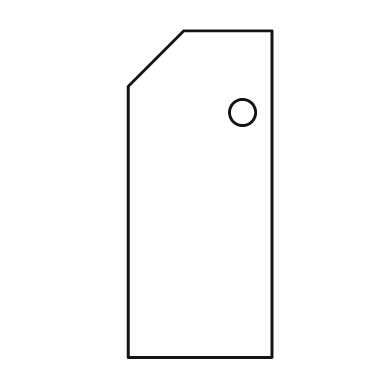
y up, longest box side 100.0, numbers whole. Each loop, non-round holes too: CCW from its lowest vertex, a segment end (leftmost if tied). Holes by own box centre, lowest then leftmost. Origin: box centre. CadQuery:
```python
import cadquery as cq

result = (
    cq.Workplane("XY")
    .moveTo(-22.0, -50.0)
    .lineTo(22.0, -50.0)
    .lineTo(22.0, 50.0)
    .lineTo(-5.0, 50.0)
    .lineTo(-22.0, 33.0)
    .close()
    .moveTo(13.0, 25.0)
    .circle(4.0)
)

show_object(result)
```